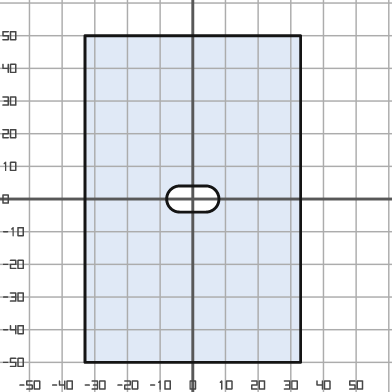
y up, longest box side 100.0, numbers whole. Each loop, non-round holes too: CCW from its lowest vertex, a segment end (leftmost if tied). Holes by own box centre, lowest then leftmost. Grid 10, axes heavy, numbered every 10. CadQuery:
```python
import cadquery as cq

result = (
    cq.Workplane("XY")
    .moveTo(-33.0, -50.0)
    .lineTo(33.0, -50.0)
    .lineTo(33.0, 50.0)
    .lineTo(-33.0, 50.0)
    .close()
    .moveTo(-4.0, -4.0)
    .lineTo(4.0, -4.0)
    .threePointArc((8.0, 0.0), (4.0, 4.0))
    .lineTo(-4.0, 4.0)
    .threePointArc((-8.0, 0.0), (-4.0, -4.0))
    .close()
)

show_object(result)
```